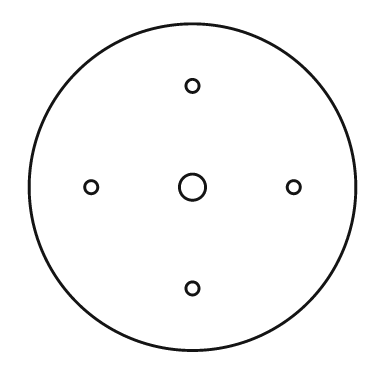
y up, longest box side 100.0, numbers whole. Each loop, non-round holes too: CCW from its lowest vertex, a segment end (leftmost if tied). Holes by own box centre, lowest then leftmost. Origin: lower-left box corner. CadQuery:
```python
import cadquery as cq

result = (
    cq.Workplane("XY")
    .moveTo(50.0, 50.0)
    .circle(50.0)
    .moveTo(50.0, 19.0)
    .circle(2.0)
    .moveTo(19.0, 50.0)
    .circle(2.0)
    .moveTo(50.0, 50.0)
    .circle(4.0)
    .moveTo(81.0, 50.0)
    .circle(2.0)
    .moveTo(50.0, 81.0)
    .circle(2.0)
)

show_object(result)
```